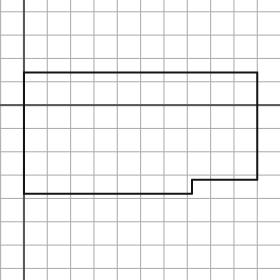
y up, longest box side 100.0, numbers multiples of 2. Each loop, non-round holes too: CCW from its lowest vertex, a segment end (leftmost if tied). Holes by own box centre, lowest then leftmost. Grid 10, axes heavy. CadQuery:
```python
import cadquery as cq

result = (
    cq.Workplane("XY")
    .moveTo(0.0, -38.0)
    .lineTo(72.0, -38.0)
    .lineTo(72.0, -32.0)
    .lineTo(100.0, -32.0)
    .lineTo(100.0, 14.0)
    .lineTo(0.0, 14.0)
    .close()
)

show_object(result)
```